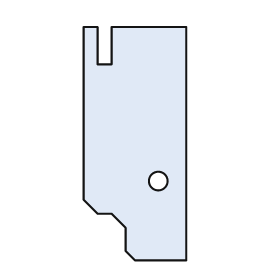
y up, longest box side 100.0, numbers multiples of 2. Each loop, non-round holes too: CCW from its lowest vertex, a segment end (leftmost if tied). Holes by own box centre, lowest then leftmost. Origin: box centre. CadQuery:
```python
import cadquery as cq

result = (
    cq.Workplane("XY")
    .moveTo(0.0, -50.0)
    .lineTo(22.0, -50.0)
    .lineTo(22.0, 50.0)
    .lineTo(-10.0, 50.0)
    .lineTo(-10.0, 34.0)
    .lineTo(-16.0, 34.0)
    .lineTo(-16.0, 50.0)
    .lineTo(-22.0, 50.0)
    .lineTo(-22.0, -24.0)
    .lineTo(-16.0, -30.0)
    .lineTo(-10.0, -30.0)
    .lineTo(-4.0, -36.0)
    .lineTo(-4.0, -46.0)
    .close()
    .moveTo(10.0, -16.0)
    .circle(4.0)
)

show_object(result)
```